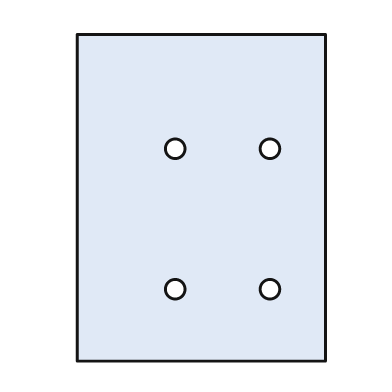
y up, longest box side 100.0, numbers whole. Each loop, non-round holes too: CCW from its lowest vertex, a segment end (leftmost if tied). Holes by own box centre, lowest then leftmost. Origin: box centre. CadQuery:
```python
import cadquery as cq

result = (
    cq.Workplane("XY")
    .moveTo(-38.0, -50.0)
    .lineTo(38.0, -50.0)
    .lineTo(38.0, 50.0)
    .lineTo(-38.0, 50.0)
    .close()
    .moveTo(-8.0, -28.0)
    .circle(3.0)
    .moveTo(21.0, -28.0)
    .circle(3.0)
    .moveTo(-8.0, 15.0)
    .circle(3.0)
    .moveTo(21.0, 15.0)
    .circle(3.0)
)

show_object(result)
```